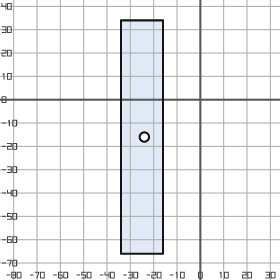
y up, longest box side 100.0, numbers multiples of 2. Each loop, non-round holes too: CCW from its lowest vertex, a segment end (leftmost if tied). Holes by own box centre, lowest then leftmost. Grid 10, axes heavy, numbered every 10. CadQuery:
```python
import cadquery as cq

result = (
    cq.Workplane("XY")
    .moveTo(-34.0, -66.0)
    .lineTo(-16.0, -66.0)
    .lineTo(-16.0, 34.0)
    .lineTo(-34.0, 34.0)
    .close()
    .moveTo(-24.0, -16.0)
    .circle(2.0)
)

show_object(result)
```